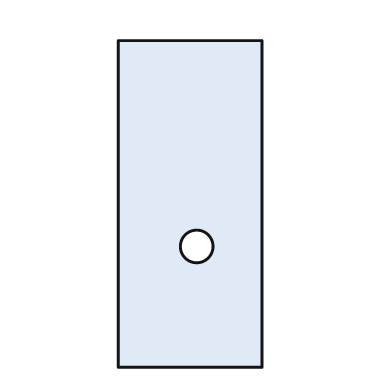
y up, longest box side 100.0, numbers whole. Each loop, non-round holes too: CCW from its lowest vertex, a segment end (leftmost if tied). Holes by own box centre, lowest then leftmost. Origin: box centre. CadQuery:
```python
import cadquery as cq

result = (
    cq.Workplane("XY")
    .moveTo(-22.0, -50.0)
    .lineTo(22.0, -50.0)
    .lineTo(22.0, 50.0)
    .lineTo(-22.0, 50.0)
    .close()
    .moveTo(2.0, -13.0)
    .circle(5.0)
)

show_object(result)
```